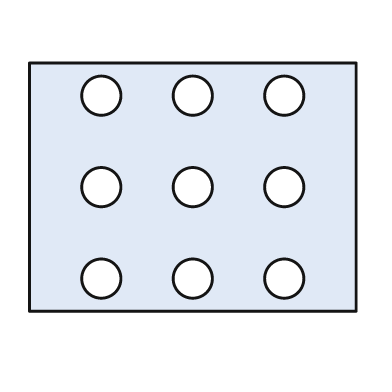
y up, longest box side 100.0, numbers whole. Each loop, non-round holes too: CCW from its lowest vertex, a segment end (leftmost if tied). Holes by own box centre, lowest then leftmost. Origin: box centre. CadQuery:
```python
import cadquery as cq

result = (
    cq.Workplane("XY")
    .moveTo(-50.0, -38.0)
    .lineTo(50.0, -38.0)
    .lineTo(50.0, 38.0)
    .lineTo(-50.0, 38.0)
    .close()
    .moveTo(-28.0, -28.0)
    .circle(6.0)
    .moveTo(0.0, -28.0)
    .circle(6.0)
    .moveTo(28.0, -28.0)
    .circle(6.0)
    .moveTo(-28.0, 0.0)
    .circle(6.0)
    .moveTo(0.0, 0.0)
    .circle(6.0)
    .moveTo(28.0, 0.0)
    .circle(6.0)
    .moveTo(-28.0, 28.0)
    .circle(6.0)
    .moveTo(0.0, 28.0)
    .circle(6.0)
    .moveTo(28.0, 28.0)
    .circle(6.0)
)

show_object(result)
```